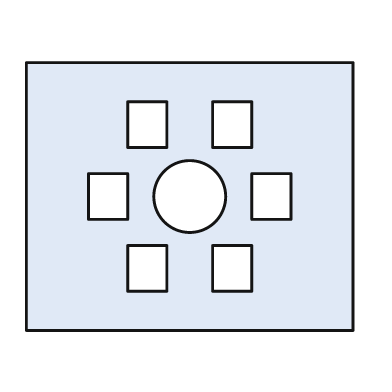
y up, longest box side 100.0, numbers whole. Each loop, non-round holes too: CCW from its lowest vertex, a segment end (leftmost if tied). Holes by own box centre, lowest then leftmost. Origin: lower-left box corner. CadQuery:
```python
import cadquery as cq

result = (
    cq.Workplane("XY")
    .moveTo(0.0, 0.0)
    .lineTo(100.0, 0.0)
    .lineTo(100.0, 82.0)
    .lineTo(0.0, 82.0)
    .close()
    .moveTo(31.0, 12.0)
    .lineTo(43.0, 12.0)
    .lineTo(43.0, 26.0)
    .lineTo(31.0, 26.0)
    .close()
    .moveTo(57.0, 12.0)
    .lineTo(69.0, 12.0)
    .lineTo(69.0, 26.0)
    .lineTo(57.0, 26.0)
    .close()
    .moveTo(19.0, 34.0)
    .lineTo(31.0, 34.0)
    .lineTo(31.0, 48.0)
    .lineTo(19.0, 48.0)
    .close()
    .moveTo(50.0, 41.0)
    .circle(11.0)
    .moveTo(69.0, 34.0)
    .lineTo(81.0, 34.0)
    .lineTo(81.0, 48.0)
    .lineTo(69.0, 48.0)
    .close()
    .moveTo(31.0, 56.0)
    .lineTo(43.0, 56.0)
    .lineTo(43.0, 70.0)
    .lineTo(31.0, 70.0)
    .close()
    .moveTo(57.0, 56.0)
    .lineTo(69.0, 56.0)
    .lineTo(69.0, 70.0)
    .lineTo(57.0, 70.0)
    .close()
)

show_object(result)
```